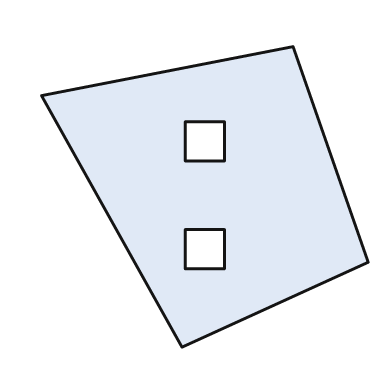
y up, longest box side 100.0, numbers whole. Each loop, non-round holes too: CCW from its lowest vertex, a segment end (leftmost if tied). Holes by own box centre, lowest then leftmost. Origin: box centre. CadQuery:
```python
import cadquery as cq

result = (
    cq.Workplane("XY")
    .moveTo(-7.0, -46.0)
    .lineTo(50.0, -20.0)
    .lineTo(27.0, 46.0)
    .lineTo(-50.0, 31.0)
    .close()
    .moveTo(-6.0, -22.0)
    .lineTo(6.0, -22.0)
    .lineTo(6.0, -10.0)
    .lineTo(-6.0, -10.0)
    .close()
    .moveTo(-6.0, 11.0)
    .lineTo(6.0, 11.0)
    .lineTo(6.0, 23.0)
    .lineTo(-6.0, 23.0)
    .close()
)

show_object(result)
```